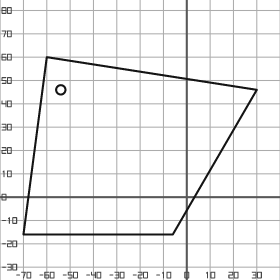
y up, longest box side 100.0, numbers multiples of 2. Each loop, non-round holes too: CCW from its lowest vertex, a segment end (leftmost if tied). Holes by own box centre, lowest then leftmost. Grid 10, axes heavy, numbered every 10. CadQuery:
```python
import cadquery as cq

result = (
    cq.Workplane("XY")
    .moveTo(-70.0, -16.0)
    .lineTo(-6.0, -16.0)
    .lineTo(30.0, 46.0)
    .lineTo(-60.0, 60.0)
    .close()
    .moveTo(-54.0, 46.0)
    .circle(2.0)
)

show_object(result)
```